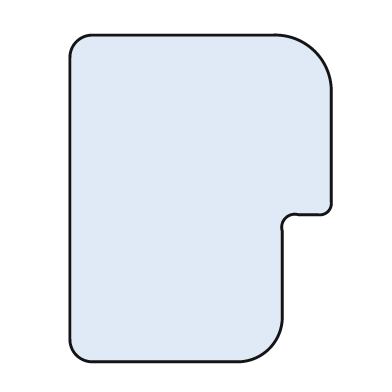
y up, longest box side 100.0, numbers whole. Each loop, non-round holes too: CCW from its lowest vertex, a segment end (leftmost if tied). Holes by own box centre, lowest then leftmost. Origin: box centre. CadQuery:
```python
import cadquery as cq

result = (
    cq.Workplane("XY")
    .moveTo(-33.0, -50.0)
    .lineTo(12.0, -50.0)
    .threePointArc((21.0, -46.0), (25.0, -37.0))
    .lineTo(25.0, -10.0)
    .threePointArc((26.0, -6.0), (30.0, -5.0))
    .lineTo(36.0, -5.0)
    .threePointArc((39.0, -4.0), (40.0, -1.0))
    .lineTo(40.0, 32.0)
    .threePointArc((35.0, 45.0), (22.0, 50.0))
    .lineTo(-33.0, 50.0)
    .threePointArc((-38.0, 48.0), (-40.0, 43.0))
    .lineTo(-40.0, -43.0)
    .threePointArc((-38.0, -48.0), (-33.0, -50.0))
    .close()
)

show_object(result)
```